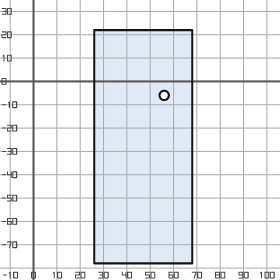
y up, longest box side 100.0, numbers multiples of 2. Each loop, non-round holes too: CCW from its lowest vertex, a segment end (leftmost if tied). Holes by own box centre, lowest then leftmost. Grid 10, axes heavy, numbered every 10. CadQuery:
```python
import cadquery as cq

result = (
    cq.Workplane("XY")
    .moveTo(26.0, -78.0)
    .lineTo(68.0, -78.0)
    .lineTo(68.0, 22.0)
    .lineTo(26.0, 22.0)
    .close()
    .moveTo(56.0, -6.0)
    .circle(2.0)
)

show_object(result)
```